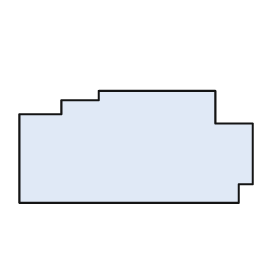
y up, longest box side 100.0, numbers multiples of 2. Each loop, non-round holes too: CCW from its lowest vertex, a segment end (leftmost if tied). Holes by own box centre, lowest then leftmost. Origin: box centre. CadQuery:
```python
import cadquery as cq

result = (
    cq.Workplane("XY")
    .moveTo(-50.0, -24.0)
    .lineTo(44.0, -24.0)
    .lineTo(44.0, -16.0)
    .lineTo(50.0, -16.0)
    .lineTo(50.0, 10.0)
    .lineTo(34.0, 10.0)
    .lineTo(34.0, 24.0)
    .lineTo(-16.0, 24.0)
    .lineTo(-16.0, 20.0)
    .lineTo(-32.0, 20.0)
    .lineTo(-32.0, 14.0)
    .lineTo(-50.0, 14.0)
    .close()
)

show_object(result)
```